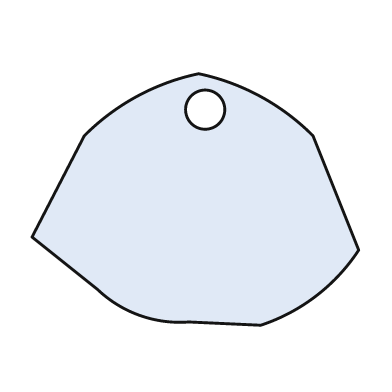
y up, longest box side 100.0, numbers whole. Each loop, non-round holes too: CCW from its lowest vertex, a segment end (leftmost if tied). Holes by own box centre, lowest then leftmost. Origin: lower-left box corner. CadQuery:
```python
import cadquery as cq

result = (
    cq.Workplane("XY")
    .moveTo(70.0, 0.0)
    .threePointArc((87.0, 9.0), (100.0, 23.0))
    .lineTo(86.0, 58.0)
    .threePointArc((70.0, 70.0), (51.0, 77.0))
    .threePointArc((32.0, 70.0), (16.0, 58.0))
    .lineTo(0.0, 27.0)
    .lineTo(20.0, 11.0)
    .threePointArc((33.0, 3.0), (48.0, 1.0))
    .close()
    .moveTo(53.0, 66.0)
    .circle(6.0)
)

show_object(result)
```